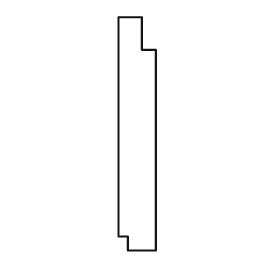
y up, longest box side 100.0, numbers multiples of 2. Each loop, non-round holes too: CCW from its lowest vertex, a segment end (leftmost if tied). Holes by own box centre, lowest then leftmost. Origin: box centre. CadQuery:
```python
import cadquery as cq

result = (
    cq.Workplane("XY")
    .moveTo(-4.0, -50.0)
    .lineTo(8.0, -50.0)
    .lineTo(8.0, 36.0)
    .lineTo(2.0, 36.0)
    .lineTo(2.0, 50.0)
    .lineTo(-8.0, 50.0)
    .lineTo(-8.0, -44.0)
    .lineTo(-4.0, -44.0)
    .close()
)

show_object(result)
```